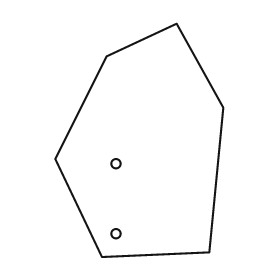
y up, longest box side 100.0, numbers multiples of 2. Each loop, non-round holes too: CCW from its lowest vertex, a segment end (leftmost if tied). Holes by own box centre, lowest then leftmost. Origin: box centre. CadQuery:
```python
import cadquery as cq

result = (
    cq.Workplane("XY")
    .moveTo(-16.0, -50.0)
    .lineTo(30.0, -48.0)
    .lineTo(36.0, 14.0)
    .lineTo(16.0, 50.0)
    .lineTo(-14.0, 36.0)
    .lineTo(-36.0, -8.0)
    .close()
    .moveTo(-10.0, -40.0)
    .circle(2.0)
    .moveTo(-10.0, -10.0)
    .circle(2.0)
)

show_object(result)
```